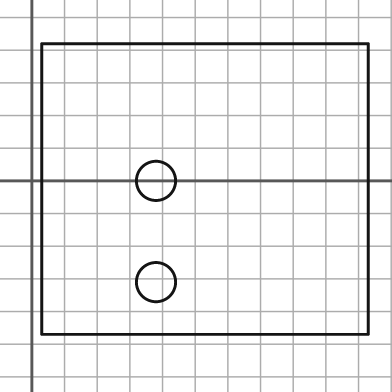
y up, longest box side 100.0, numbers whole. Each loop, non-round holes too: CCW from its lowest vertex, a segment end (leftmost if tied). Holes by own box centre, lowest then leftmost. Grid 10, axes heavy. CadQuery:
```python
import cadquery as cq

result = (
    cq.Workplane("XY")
    .moveTo(3.0, -47.0)
    .lineTo(103.0, -47.0)
    .lineTo(103.0, 42.0)
    .lineTo(3.0, 42.0)
    .close()
    .moveTo(38.0, -31.0)
    .circle(6.0)
    .moveTo(38.0, 0.0)
    .circle(6.0)
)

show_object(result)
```